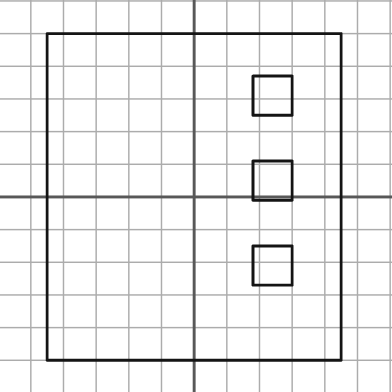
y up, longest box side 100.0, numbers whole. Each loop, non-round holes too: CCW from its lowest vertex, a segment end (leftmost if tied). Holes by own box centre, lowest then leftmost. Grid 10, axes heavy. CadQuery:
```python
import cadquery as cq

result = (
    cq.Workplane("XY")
    .moveTo(-45.0, -50.0)
    .lineTo(45.0, -50.0)
    .lineTo(45.0, 50.0)
    .lineTo(-45.0, 50.0)
    .close()
    .moveTo(18.0, -27.0)
    .lineTo(30.0, -27.0)
    .lineTo(30.0, -15.0)
    .lineTo(18.0, -15.0)
    .close()
    .moveTo(18.0, -1.0)
    .lineTo(30.0, -1.0)
    .lineTo(30.0, 11.0)
    .lineTo(18.0, 11.0)
    .close()
    .moveTo(18.0, 25.0)
    .lineTo(30.0, 25.0)
    .lineTo(30.0, 37.0)
    .lineTo(18.0, 37.0)
    .close()
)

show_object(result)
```